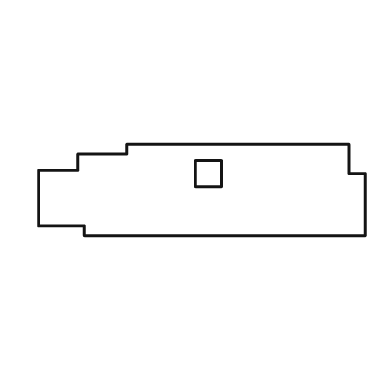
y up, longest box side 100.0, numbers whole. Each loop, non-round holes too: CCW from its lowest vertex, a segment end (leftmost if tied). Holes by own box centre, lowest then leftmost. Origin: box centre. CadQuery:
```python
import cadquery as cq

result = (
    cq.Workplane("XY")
    .moveTo(-36.0, -14.0)
    .lineTo(50.0, -14.0)
    .lineTo(50.0, 5.0)
    .lineTo(45.0, 5.0)
    .lineTo(45.0, 14.0)
    .lineTo(-23.0, 14.0)
    .lineTo(-23.0, 11.0)
    .lineTo(-38.0, 11.0)
    .lineTo(-38.0, 6.0)
    .lineTo(-50.0, 6.0)
    .lineTo(-50.0, -11.0)
    .lineTo(-36.0, -11.0)
    .close()
    .moveTo(-2.0, 1.0)
    .lineTo(6.0, 1.0)
    .lineTo(6.0, 9.0)
    .lineTo(-2.0, 9.0)
    .close()
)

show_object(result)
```